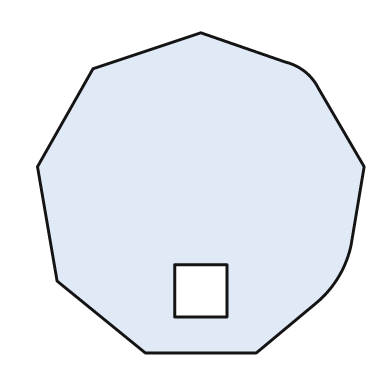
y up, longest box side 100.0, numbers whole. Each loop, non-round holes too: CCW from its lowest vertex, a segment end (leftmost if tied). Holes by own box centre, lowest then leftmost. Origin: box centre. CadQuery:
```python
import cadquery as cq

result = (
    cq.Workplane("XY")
    .moveTo(-17.0, -49.0)
    .lineTo(17.0, -49.0)
    .lineTo(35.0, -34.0)
    .threePointArc((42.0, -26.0), (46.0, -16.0))
    .lineTo(50.0, 8.0)
    .lineTo(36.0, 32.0)
    .threePointArc((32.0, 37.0), (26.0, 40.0))
    .lineTo(0.0, 49.0)
    .lineTo(-33.0, 38.0)
    .lineTo(-50.0, 8.0)
    .lineTo(-44.0, -27.0)
    .close()
    .moveTo(-8.0, -38.0)
    .lineTo(8.0, -38.0)
    .lineTo(8.0, -22.0)
    .lineTo(-8.0, -22.0)
    .close()
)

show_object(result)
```